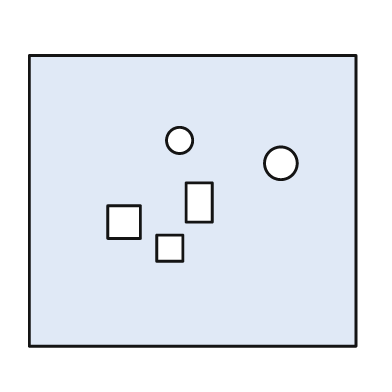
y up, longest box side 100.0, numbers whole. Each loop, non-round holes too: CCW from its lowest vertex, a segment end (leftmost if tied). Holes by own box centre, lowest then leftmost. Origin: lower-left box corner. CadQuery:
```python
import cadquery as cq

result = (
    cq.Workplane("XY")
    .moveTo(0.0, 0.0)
    .lineTo(100.0, 0.0)
    .lineTo(100.0, 89.0)
    .lineTo(0.0, 89.0)
    .close()
    .moveTo(39.0, 26.0)
    .lineTo(47.0, 26.0)
    .lineTo(47.0, 34.0)
    .lineTo(39.0, 34.0)
    .close()
    .moveTo(24.0, 33.0)
    .lineTo(34.0, 33.0)
    .lineTo(34.0, 43.0)
    .lineTo(24.0, 43.0)
    .close()
    .moveTo(48.0, 38.0)
    .lineTo(56.0, 38.0)
    .lineTo(56.0, 50.0)
    .lineTo(48.0, 50.0)
    .close()
    .moveTo(77.0, 56.0)
    .circle(5.0)
    .moveTo(46.0, 63.0)
    .circle(4.0)
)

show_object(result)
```